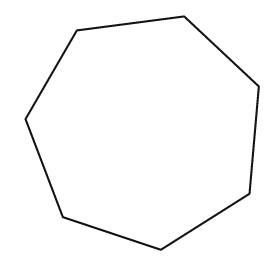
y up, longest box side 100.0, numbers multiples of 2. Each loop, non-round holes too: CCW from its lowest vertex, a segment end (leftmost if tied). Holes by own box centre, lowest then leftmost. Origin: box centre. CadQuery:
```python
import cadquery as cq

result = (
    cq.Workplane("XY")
    .moveTo(8.0, -50.0)
    .lineTo(46.0, -26.0)
    .lineTo(50.0, 20.0)
    .lineTo(18.0, 50.0)
    .lineTo(-28.0, 44.0)
    .lineTo(-50.0, 6.0)
    .lineTo(-34.0, -36.0)
    .close()
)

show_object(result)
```